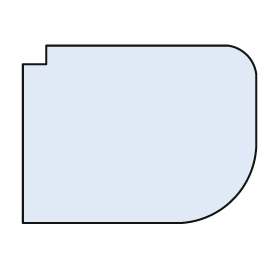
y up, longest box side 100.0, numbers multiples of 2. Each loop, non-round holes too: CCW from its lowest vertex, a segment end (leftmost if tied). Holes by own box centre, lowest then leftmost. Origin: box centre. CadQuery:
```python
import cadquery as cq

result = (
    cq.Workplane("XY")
    .moveTo(-50.0, -38.0)
    .lineTo(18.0, -38.0)
    .threePointArc((40.0, -28.0), (50.0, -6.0))
    .lineTo(50.0, 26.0)
    .threePointArc((46.0, 34.0), (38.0, 38.0))
    .lineTo(-40.0, 38.0)
    .lineTo(-40.0, 30.0)
    .lineTo(-50.0, 30.0)
    .close()
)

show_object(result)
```